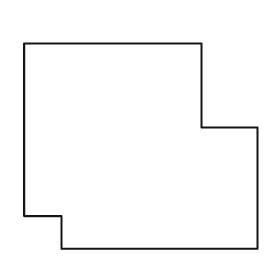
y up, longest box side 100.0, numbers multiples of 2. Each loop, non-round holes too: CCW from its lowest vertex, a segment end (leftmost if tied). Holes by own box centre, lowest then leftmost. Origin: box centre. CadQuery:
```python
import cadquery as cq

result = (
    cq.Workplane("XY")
    .moveTo(-34.0, -44.0)
    .lineTo(50.0, -44.0)
    .lineTo(50.0, 8.0)
    .lineTo(26.0, 8.0)
    .lineTo(26.0, 44.0)
    .lineTo(-50.0, 44.0)
    .lineTo(-50.0, -30.0)
    .lineTo(-34.0, -30.0)
    .close()
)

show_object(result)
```